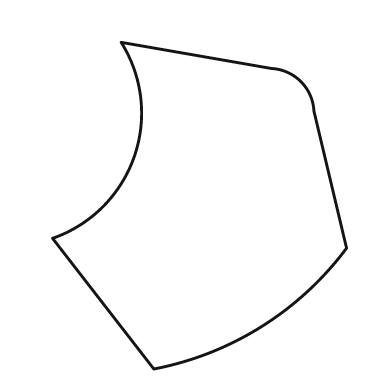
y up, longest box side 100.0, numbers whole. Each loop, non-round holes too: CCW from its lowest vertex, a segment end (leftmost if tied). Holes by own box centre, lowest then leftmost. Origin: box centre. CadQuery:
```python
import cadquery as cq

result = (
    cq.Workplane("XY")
    .moveTo(-14.0, -50.0)
    .threePointArc((19.0, -37.0), (45.0, -13.0))
    .lineTo(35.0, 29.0)
    .threePointArc((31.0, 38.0), (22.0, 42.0))
    .lineTo(-24.0, 50.0)
    .threePointArc((-20.0, 15.0), (-45.0, -10.0))
    .close()
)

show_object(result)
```